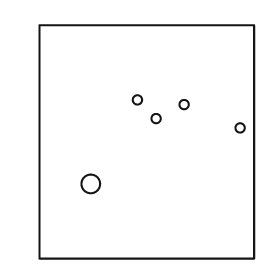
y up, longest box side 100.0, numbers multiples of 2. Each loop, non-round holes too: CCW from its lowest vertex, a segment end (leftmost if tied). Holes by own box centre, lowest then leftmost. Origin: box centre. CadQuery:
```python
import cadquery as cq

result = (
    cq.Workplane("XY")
    .moveTo(-46.0, -50.0)
    .lineTo(46.0, -50.0)
    .lineTo(46.0, 50.0)
    .lineTo(-46.0, 50.0)
    .close()
    .moveTo(-24.0, -18.0)
    .circle(4.0)
    .moveTo(40.0, 6.0)
    .circle(2.0)
    .moveTo(4.0, 10.0)
    .circle(2.0)
    .moveTo(16.0, 16.0)
    .circle(2.0)
    .moveTo(-4.0, 18.0)
    .circle(2.0)
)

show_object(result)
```